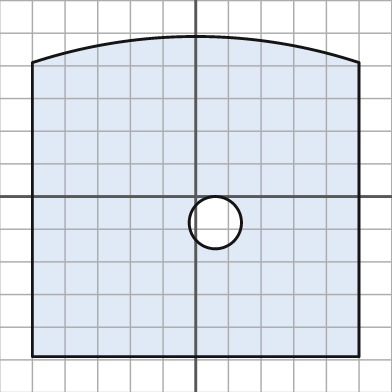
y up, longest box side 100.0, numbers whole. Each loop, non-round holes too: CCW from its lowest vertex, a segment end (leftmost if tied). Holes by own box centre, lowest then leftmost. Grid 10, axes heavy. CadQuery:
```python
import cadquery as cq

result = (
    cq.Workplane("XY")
    .moveTo(-50.0, -49.0)
    .lineTo(50.0, -49.0)
    .lineTo(50.0, 41.0)
    .threePointArc((0.0, 49.0), (-50.0, 41.0))
    .close()
    .moveTo(6.0, -8.0)
    .circle(8.0)
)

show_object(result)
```